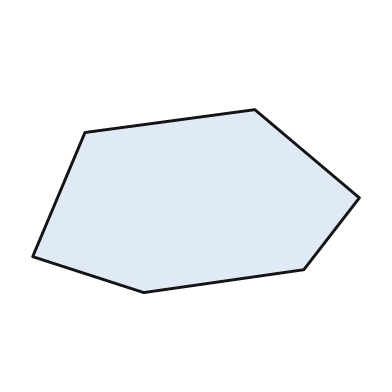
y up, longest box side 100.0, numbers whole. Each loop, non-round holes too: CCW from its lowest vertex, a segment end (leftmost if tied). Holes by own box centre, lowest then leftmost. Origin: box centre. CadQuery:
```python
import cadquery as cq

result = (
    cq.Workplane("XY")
    .moveTo(-16.0, -28.0)
    .lineTo(33.0, -21.0)
    .lineTo(50.0, 1.0)
    .lineTo(18.0, 28.0)
    .lineTo(-34.0, 21.0)
    .lineTo(-50.0, -17.0)
    .close()
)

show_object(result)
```